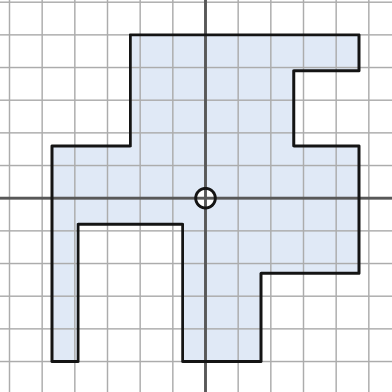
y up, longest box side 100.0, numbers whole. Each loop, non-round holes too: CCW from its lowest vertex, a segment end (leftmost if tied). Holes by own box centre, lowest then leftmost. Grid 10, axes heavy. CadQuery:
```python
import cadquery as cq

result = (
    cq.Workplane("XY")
    .moveTo(-47.0, -50.0)
    .lineTo(-39.0, -50.0)
    .lineTo(-39.0, -8.0)
    .lineTo(-7.0, -8.0)
    .lineTo(-7.0, -50.0)
    .lineTo(17.0, -50.0)
    .lineTo(17.0, -23.0)
    .lineTo(47.0, -23.0)
    .lineTo(47.0, 16.0)
    .lineTo(27.0, 16.0)
    .lineTo(27.0, 39.0)
    .lineTo(47.0, 39.0)
    .lineTo(47.0, 50.0)
    .lineTo(-23.0, 50.0)
    .lineTo(-23.0, 16.0)
    .lineTo(-47.0, 16.0)
    .close()
    .moveTo(0.0, 0.0)
    .circle(3.0)
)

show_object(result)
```